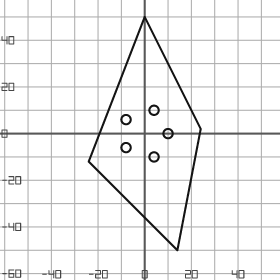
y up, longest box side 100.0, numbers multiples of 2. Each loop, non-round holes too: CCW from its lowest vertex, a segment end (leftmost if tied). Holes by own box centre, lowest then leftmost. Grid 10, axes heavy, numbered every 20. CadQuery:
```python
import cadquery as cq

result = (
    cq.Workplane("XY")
    .moveTo(14.0, -50.0)
    .lineTo(24.0, 2.0)
    .lineTo(0.0, 50.0)
    .lineTo(-24.0, -12.0)
    .close()
    .moveTo(4.0, -10.0)
    .circle(2.0)
    .moveTo(-8.0, -6.0)
    .circle(2.0)
    .moveTo(10.0, 0.0)
    .circle(2.0)
    .moveTo(-8.0, 6.0)
    .circle(2.0)
    .moveTo(4.0, 10.0)
    .circle(2.0)
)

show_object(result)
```